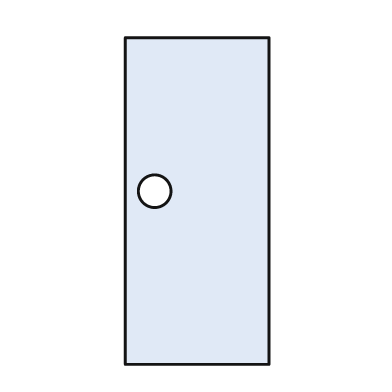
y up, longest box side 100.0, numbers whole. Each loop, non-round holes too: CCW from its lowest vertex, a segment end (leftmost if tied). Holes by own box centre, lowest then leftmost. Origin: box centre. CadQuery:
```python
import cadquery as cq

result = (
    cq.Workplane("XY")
    .moveTo(-22.0, -50.0)
    .lineTo(22.0, -50.0)
    .lineTo(22.0, 50.0)
    .lineTo(-22.0, 50.0)
    .close()
    .moveTo(-13.0, 3.0)
    .circle(5.0)
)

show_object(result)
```